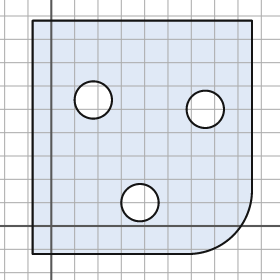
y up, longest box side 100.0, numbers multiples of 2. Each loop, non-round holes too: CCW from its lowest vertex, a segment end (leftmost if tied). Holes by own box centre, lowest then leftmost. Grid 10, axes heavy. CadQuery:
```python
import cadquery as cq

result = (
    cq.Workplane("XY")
    .moveTo(-8.0, -12.0)
    .lineTo(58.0, -12.0)
    .threePointArc((78.0, -4.0), (86.0, 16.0))
    .lineTo(86.0, 88.0)
    .lineTo(-8.0, 88.0)
    .close()
    .moveTo(38.0, 10.0)
    .circle(8.0)
    .moveTo(66.0, 50.0)
    .circle(8.0)
    .moveTo(18.0, 54.0)
    .circle(8.0)
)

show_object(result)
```